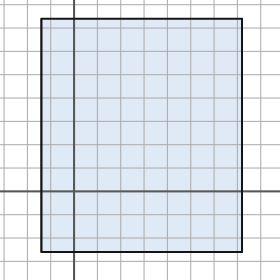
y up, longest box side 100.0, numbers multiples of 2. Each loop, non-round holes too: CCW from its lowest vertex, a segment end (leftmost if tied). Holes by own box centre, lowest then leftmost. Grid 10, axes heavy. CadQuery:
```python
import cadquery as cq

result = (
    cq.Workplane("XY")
    .moveTo(-14.0, -26.0)
    .lineTo(72.0, -26.0)
    .lineTo(72.0, 74.0)
    .lineTo(-14.0, 74.0)
    .close()
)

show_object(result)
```